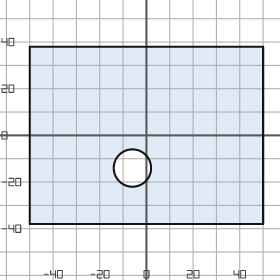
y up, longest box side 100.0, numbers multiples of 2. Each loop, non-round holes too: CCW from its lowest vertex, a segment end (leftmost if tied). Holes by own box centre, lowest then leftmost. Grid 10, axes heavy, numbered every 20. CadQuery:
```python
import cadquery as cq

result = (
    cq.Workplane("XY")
    .moveTo(-50.0, -38.0)
    .lineTo(50.0, -38.0)
    .lineTo(50.0, 38.0)
    .lineTo(-50.0, 38.0)
    .close()
    .moveTo(-6.0, -14.0)
    .circle(8.0)
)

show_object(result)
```